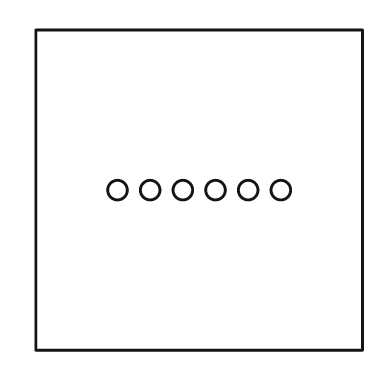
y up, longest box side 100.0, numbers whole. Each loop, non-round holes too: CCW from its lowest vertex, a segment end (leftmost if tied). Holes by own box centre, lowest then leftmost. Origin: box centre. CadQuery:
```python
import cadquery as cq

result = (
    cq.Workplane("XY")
    .moveTo(-50.0, -49.0)
    .lineTo(50.0, -49.0)
    .lineTo(50.0, 49.0)
    .lineTo(-50.0, 49.0)
    .close()
    .moveTo(-25.0, 0.0)
    .circle(3.0)
    .moveTo(-15.0, 0.0)
    .circle(3.0)
    .moveTo(-5.0, 0.0)
    .circle(3.0)
    .moveTo(5.0, 0.0)
    .circle(3.0)
    .moveTo(15.0, 0.0)
    .circle(3.0)
    .moveTo(25.0, 0.0)
    .circle(3.0)
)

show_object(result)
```